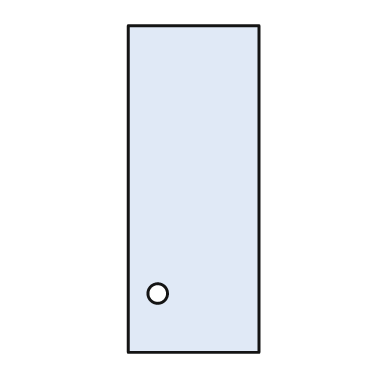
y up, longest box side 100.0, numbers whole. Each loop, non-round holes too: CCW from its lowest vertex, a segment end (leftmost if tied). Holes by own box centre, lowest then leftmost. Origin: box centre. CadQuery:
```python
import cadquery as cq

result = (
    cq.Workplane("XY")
    .moveTo(-20.0, -50.0)
    .lineTo(20.0, -50.0)
    .lineTo(20.0, 50.0)
    .lineTo(-20.0, 50.0)
    .close()
    .moveTo(-11.0, -32.0)
    .circle(3.0)
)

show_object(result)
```